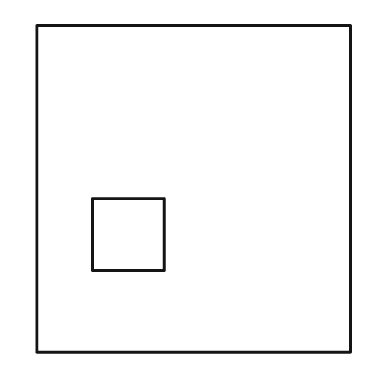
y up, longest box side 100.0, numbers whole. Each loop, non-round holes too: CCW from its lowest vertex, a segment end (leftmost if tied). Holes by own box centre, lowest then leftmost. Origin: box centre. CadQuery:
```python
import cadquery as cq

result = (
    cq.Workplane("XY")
    .moveTo(-48.0, -50.0)
    .lineTo(48.0, -50.0)
    .lineTo(48.0, 50.0)
    .lineTo(-48.0, 50.0)
    .close()
    .moveTo(-31.0, -25.0)
    .lineTo(-9.0, -25.0)
    .lineTo(-9.0, -3.0)
    .lineTo(-31.0, -3.0)
    .close()
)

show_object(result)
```